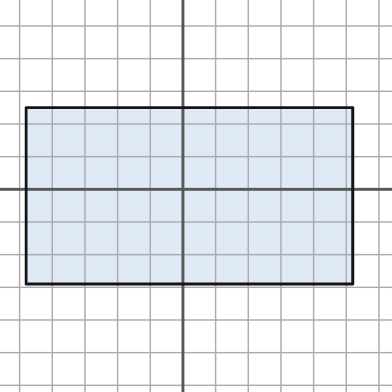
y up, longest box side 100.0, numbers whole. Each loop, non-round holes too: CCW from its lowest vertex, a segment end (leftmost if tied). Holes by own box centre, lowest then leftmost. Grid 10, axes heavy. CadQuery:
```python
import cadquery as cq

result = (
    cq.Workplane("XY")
    .moveTo(-48.0, -29.0)
    .lineTo(52.0, -29.0)
    .lineTo(52.0, 25.0)
    .lineTo(-48.0, 25.0)
    .close()
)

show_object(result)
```